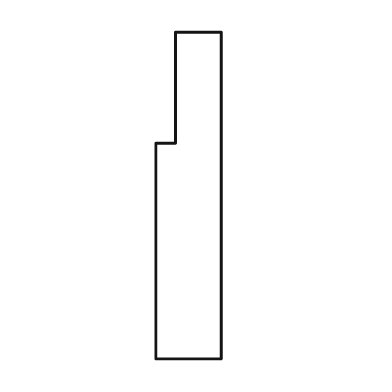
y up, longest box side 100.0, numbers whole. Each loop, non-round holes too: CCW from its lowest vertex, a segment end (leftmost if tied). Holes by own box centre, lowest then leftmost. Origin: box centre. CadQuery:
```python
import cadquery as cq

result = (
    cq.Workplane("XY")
    .moveTo(-10.0, -50.0)
    .lineTo(10.0, -50.0)
    .lineTo(10.0, 50.0)
    .lineTo(-4.0, 50.0)
    .lineTo(-4.0, 16.0)
    .lineTo(-10.0, 16.0)
    .close()
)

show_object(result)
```